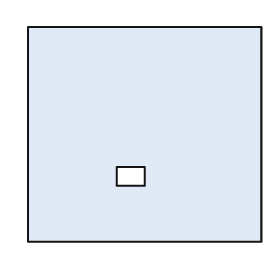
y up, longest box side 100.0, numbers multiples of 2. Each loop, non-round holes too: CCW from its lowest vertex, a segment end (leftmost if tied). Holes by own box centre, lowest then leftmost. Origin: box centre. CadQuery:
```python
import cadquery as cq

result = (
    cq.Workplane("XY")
    .moveTo(-50.0, -46.0)
    .lineTo(50.0, -46.0)
    .lineTo(50.0, 46.0)
    .lineTo(-50.0, 46.0)
    .close()
    .moveTo(-12.0, -22.0)
    .lineTo(0.0, -22.0)
    .lineTo(0.0, -14.0)
    .lineTo(-12.0, -14.0)
    .close()
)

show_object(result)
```